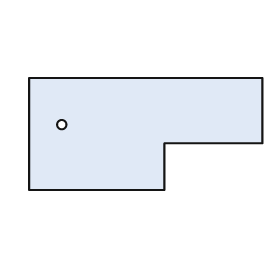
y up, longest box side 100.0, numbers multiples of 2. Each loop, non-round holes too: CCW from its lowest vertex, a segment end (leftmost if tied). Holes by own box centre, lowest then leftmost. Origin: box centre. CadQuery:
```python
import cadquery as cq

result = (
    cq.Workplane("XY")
    .moveTo(-50.0, -24.0)
    .lineTo(8.0, -24.0)
    .lineTo(8.0, -4.0)
    .lineTo(50.0, -4.0)
    .lineTo(50.0, 24.0)
    .lineTo(-50.0, 24.0)
    .close()
    .moveTo(-36.0, 4.0)
    .circle(2.0)
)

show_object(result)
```